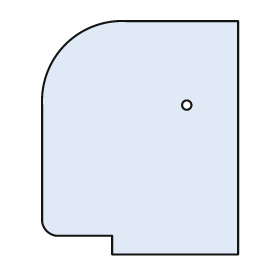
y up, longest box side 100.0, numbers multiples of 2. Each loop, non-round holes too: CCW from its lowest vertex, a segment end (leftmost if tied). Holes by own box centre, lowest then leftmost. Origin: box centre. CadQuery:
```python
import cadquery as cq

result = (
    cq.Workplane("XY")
    .moveTo(-12.0, -50.0)
    .lineTo(42.0, -50.0)
    .lineTo(42.0, 50.0)
    .lineTo(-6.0, 50.0)
    .threePointArc((-32.0, 40.0), (-42.0, 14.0))
    .lineTo(-42.0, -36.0)
    .threePointArc((-40.0, -40.0), (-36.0, -42.0))
    .lineTo(-12.0, -42.0)
    .close()
    .moveTo(20.0, 14.0)
    .circle(2.0)
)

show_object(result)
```